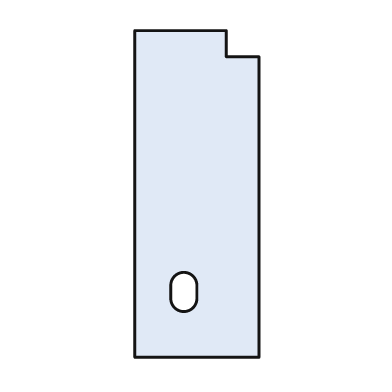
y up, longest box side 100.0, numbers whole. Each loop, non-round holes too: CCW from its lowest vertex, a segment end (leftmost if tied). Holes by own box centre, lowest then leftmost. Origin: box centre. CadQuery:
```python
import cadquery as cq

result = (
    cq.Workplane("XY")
    .moveTo(-19.0, -50.0)
    .lineTo(19.0, -50.0)
    .lineTo(19.0, 42.0)
    .lineTo(9.0, 42.0)
    .lineTo(9.0, 50.0)
    .lineTo(-19.0, 50.0)
    .close()
    .moveTo(-8.0, -32.0)
    .threePointArc((-4.0, -36.0), (0.0, -32.0))
    .lineTo(0.0, -28.0)
    .threePointArc((-4.0, -24.0), (-8.0, -28.0))
    .close()
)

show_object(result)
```